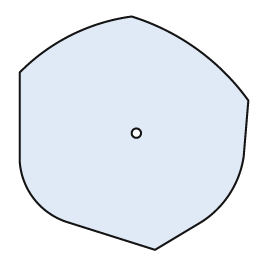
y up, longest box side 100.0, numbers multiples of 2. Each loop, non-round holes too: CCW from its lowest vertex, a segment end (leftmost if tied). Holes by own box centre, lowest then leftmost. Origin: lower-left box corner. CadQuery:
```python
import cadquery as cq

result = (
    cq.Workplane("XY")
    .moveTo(58.0, 0.0)
    .lineTo(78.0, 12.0)
    .threePointArc((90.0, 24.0), (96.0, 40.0))
    .lineTo(98.0, 64.0)
    .threePointArc((76.0, 86.0), (48.0, 100.0))
    .threePointArc((22.0, 92.0), (0.0, 76.0))
    .lineTo(0.0, 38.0)
    .threePointArc((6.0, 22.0), (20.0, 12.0))
    .close()
    .moveTo(50.0, 50.0)
    .circle(2.0)
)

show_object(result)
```